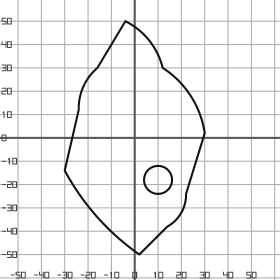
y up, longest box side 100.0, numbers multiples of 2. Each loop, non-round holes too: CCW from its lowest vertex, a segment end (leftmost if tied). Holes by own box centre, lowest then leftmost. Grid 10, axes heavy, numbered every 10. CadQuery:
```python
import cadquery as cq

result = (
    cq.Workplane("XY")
    .moveTo(2.0, -50.0)
    .lineTo(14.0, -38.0)
    .threePointArc((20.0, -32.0), (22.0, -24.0))
    .lineTo(30.0, 2.0)
    .threePointArc((24.0, 18.0), (12.0, 30.0))
    .threePointArc((6.0, 42.0), (-4.0, 50.0))
    .lineTo(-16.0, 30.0)
    .threePointArc((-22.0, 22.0), (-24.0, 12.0))
    .lineTo(-30.0, -14.0)
    .threePointArc((-16.0, -34.0), (2.0, -50.0))
    .close()
    .moveTo(10.0, -18.0)
    .circle(6.0)
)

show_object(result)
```